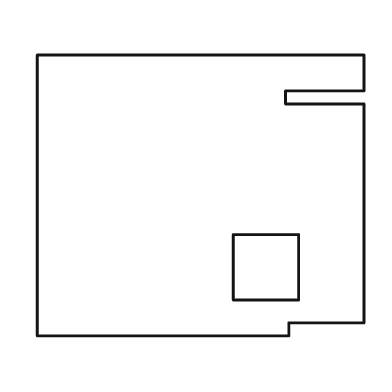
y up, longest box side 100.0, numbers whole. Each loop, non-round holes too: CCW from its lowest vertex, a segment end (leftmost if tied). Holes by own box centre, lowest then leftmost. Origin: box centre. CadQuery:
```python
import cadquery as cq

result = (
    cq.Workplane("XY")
    .moveTo(-50.0, -43.0)
    .lineTo(27.0, -43.0)
    .lineTo(27.0, -39.0)
    .lineTo(50.0, -39.0)
    .lineTo(50.0, 28.0)
    .lineTo(26.0, 28.0)
    .lineTo(26.0, 32.0)
    .lineTo(50.0, 32.0)
    .lineTo(50.0, 43.0)
    .lineTo(-50.0, 43.0)
    .close()
    .moveTo(10.0, -32.0)
    .lineTo(30.0, -32.0)
    .lineTo(30.0, -12.0)
    .lineTo(10.0, -12.0)
    .close()
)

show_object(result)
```